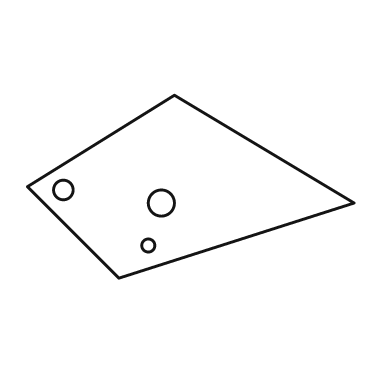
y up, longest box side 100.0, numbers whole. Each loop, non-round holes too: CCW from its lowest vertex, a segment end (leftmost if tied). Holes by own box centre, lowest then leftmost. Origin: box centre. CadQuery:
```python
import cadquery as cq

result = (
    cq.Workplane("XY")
    .moveTo(-22.0, -28.0)
    .lineTo(50.0, -5.0)
    .lineTo(-5.0, 28.0)
    .lineTo(-50.0, 0.0)
    .close()
    .moveTo(-13.0, -18.0)
    .circle(2.0)
    .moveTo(-9.0, -5.0)
    .circle(4.0)
    .moveTo(-39.0, -1.0)
    .circle(3.0)
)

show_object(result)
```